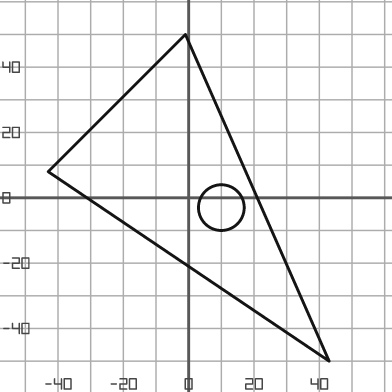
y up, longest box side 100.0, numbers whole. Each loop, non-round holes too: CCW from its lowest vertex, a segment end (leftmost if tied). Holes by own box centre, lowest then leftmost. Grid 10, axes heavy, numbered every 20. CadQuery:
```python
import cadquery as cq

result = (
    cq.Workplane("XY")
    .moveTo(43.0, -50.0)
    .lineTo(-1.0, 50.0)
    .lineTo(-43.0, 8.0)
    .close()
    .moveTo(10.0, -3.0)
    .circle(7.0)
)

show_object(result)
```